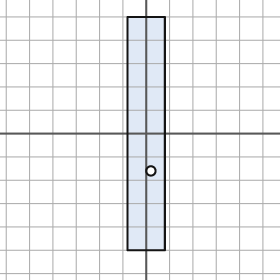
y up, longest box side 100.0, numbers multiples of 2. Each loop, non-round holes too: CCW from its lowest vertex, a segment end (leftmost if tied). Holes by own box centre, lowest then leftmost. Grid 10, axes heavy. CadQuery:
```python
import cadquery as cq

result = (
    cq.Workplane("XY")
    .moveTo(-8.0, -50.0)
    .lineTo(8.0, -50.0)
    .lineTo(8.0, 50.0)
    .lineTo(-8.0, 50.0)
    .close()
    .moveTo(2.0, -16.0)
    .circle(2.0)
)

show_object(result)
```